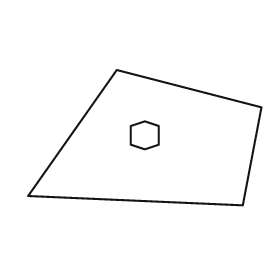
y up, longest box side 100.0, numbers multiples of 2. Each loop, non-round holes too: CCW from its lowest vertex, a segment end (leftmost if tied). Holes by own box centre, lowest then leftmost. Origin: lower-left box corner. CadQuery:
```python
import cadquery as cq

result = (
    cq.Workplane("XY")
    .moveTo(92.0, 0.0)
    .lineTo(100.0, 42.0)
    .lineTo(38.0, 58.0)
    .lineTo(0.0, 4.0)
    .close()
    .moveTo(50.0, 24.0)
    .lineTo(56.0, 26.0)
    .lineTo(56.0, 34.0)
    .lineTo(50.0, 36.0)
    .lineTo(44.0, 34.0)
    .lineTo(44.0, 26.0)
    .close()
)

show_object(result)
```